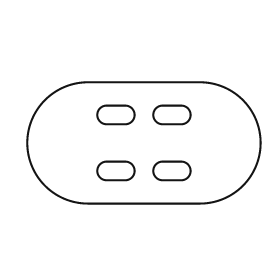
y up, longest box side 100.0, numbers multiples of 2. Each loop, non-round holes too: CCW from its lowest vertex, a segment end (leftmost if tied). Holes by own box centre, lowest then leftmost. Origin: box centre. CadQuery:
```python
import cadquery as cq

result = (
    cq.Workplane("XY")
    .moveTo(-24.0, -26.0)
    .lineTo(24.0, -26.0)
    .threePointArc((50.0, 0.0), (24.0, 26.0))
    .lineTo(-24.0, 26.0)
    .threePointArc((-50.0, 0.0), (-24.0, -26.0))
    .close()
    .moveTo(-16.0, -16.0)
    .lineTo(-8.0, -16.0)
    .threePointArc((-4.0, -12.0), (-8.0, -8.0))
    .lineTo(-16.0, -8.0)
    .threePointArc((-20.0, -12.0), (-16.0, -16.0))
    .close()
    .moveTo(8.0, -16.0)
    .lineTo(16.0, -16.0)
    .threePointArc((20.0, -12.0), (16.0, -8.0))
    .lineTo(8.0, -8.0)
    .threePointArc((4.0, -12.0), (8.0, -16.0))
    .close()
    .moveTo(-16.0, 8.0)
    .lineTo(-8.0, 8.0)
    .threePointArc((-4.0, 12.0), (-8.0, 16.0))
    .lineTo(-16.0, 16.0)
    .threePointArc((-20.0, 12.0), (-16.0, 8.0))
    .close()
    .moveTo(8.0, 8.0)
    .lineTo(16.0, 8.0)
    .threePointArc((20.0, 12.0), (16.0, 16.0))
    .lineTo(8.0, 16.0)
    .threePointArc((4.0, 12.0), (8.0, 8.0))
    .close()
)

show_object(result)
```